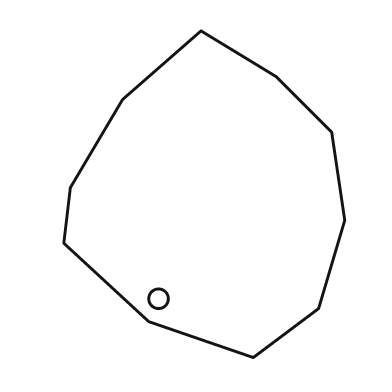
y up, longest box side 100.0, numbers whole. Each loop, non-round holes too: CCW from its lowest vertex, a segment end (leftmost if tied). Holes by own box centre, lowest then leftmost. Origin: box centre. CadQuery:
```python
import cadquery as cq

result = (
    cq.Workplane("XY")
    .moveTo(15.0, -50.0)
    .lineTo(35.0, -35.0)
    .lineTo(43.0, -8.0)
    .lineTo(39.0, 19.0)
    .lineTo(22.0, 36.0)
    .lineTo(-1.0, 50.0)
    .lineTo(-25.0, 29.0)
    .lineTo(-41.0, 2.0)
    .lineTo(-43.0, -15.0)
    .lineTo(-17.0, -39.0)
    .close()
    .moveTo(-14.0, -32.0)
    .circle(3.0)
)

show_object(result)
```